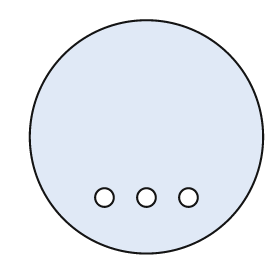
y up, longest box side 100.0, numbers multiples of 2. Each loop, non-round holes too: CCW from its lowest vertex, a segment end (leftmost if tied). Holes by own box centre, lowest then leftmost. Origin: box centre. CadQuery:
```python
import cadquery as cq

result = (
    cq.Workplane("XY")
    .moveTo(0.0, 0.0)
    .circle(50.0)
    .moveTo(-18.0, -26.0)
    .circle(4.0)
    .moveTo(0.0, -26.0)
    .circle(4.0)
    .moveTo(18.0, -26.0)
    .circle(4.0)
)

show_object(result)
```